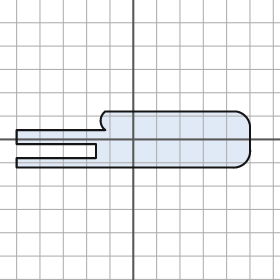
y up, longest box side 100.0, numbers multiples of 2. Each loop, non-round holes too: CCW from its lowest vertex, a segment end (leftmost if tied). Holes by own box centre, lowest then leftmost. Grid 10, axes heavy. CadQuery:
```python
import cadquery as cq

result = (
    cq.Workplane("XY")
    .moveTo(-50.0, -12.0)
    .lineTo(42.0, -12.0)
    .threePointArc((48.0, -10.0), (50.0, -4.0))
    .lineTo(50.0, 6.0)
    .threePointArc((48.0, 10.0), (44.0, 12.0))
    .lineTo(-12.0, 12.0)
    .threePointArc((-14.0, 8.0), (-12.0, 4.0))
    .lineTo(-50.0, 4.0)
    .lineTo(-50.0, -2.0)
    .lineTo(-16.0, -2.0)
    .lineTo(-16.0, -8.0)
    .lineTo(-50.0, -8.0)
    .close()
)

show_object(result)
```